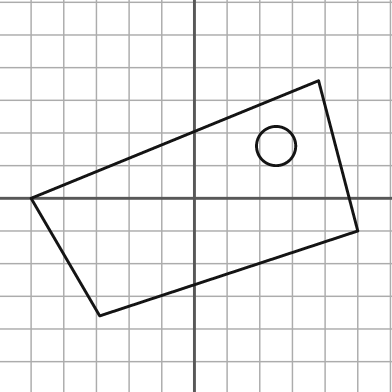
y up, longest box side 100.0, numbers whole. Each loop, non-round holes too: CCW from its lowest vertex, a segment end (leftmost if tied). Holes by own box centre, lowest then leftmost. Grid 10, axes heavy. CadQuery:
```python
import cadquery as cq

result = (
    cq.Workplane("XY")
    .moveTo(-29.0, -36.0)
    .lineTo(50.0, -10.0)
    .lineTo(38.0, 36.0)
    .lineTo(-50.0, 0.0)
    .close()
    .moveTo(25.0, 16.0)
    .circle(6.0)
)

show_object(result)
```